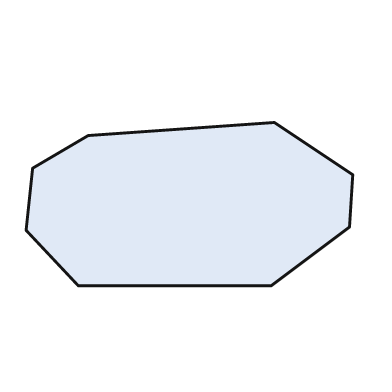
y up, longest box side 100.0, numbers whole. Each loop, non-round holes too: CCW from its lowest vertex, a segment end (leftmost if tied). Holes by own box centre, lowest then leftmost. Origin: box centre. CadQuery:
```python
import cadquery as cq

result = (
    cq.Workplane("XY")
    .moveTo(-34.0, -25.0)
    .lineTo(25.0, -25.0)
    .lineTo(49.0, -7.0)
    .lineTo(50.0, 9.0)
    .lineTo(26.0, 25.0)
    .lineTo(-31.0, 21.0)
    .lineTo(-48.0, 11.0)
    .lineTo(-50.0, -8.0)
    .close()
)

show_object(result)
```